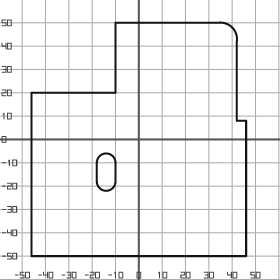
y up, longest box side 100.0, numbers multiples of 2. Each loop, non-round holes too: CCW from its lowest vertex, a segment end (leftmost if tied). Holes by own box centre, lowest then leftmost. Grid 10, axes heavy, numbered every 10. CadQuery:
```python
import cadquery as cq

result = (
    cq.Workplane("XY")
    .moveTo(-46.0, -50.0)
    .lineTo(46.0, -50.0)
    .lineTo(46.0, 8.0)
    .lineTo(42.0, 8.0)
    .lineTo(42.0, 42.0)
    .threePointArc((40.0, 48.0), (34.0, 50.0))
    .lineTo(-10.0, 50.0)
    .lineTo(-10.0, 20.0)
    .lineTo(-46.0, 20.0)
    .close()
    .moveTo(-18.0, -18.0)
    .threePointArc((-14.0, -22.0), (-10.0, -18.0))
    .lineTo(-10.0, -10.0)
    .threePointArc((-14.0, -6.0), (-18.0, -10.0))
    .close()
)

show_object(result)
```